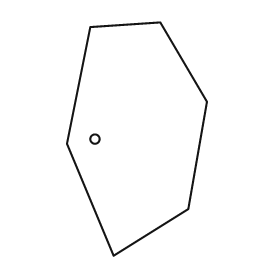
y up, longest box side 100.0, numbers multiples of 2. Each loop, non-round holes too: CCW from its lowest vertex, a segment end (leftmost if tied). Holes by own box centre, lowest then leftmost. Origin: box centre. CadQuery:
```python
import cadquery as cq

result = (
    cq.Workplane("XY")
    .moveTo(-10.0, -50.0)
    .lineTo(22.0, -30.0)
    .lineTo(30.0, 16.0)
    .lineTo(10.0, 50.0)
    .lineTo(-20.0, 48.0)
    .lineTo(-30.0, -2.0)
    .close()
    .moveTo(-18.0, 0.0)
    .circle(2.0)
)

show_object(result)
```